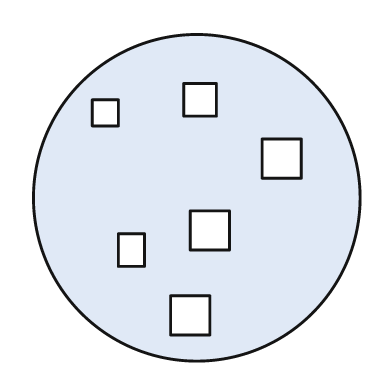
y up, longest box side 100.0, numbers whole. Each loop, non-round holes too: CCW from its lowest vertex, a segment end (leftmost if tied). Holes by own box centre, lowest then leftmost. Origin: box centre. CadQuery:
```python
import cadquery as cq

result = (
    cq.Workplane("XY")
    .moveTo(0.0, 0.0)
    .circle(50.0)
    .moveTo(-8.0, -42.0)
    .lineTo(4.0, -42.0)
    .lineTo(4.0, -30.0)
    .lineTo(-8.0, -30.0)
    .close()
    .moveTo(-24.0, -21.0)
    .lineTo(-16.0, -21.0)
    .lineTo(-16.0, -11.0)
    .lineTo(-24.0, -11.0)
    .close()
    .moveTo(-2.0, -16.0)
    .lineTo(10.0, -16.0)
    .lineTo(10.0, -4.0)
    .lineTo(-2.0, -4.0)
    .close()
    .moveTo(20.0, 6.0)
    .lineTo(32.0, 6.0)
    .lineTo(32.0, 18.0)
    .lineTo(20.0, 18.0)
    .close()
    .moveTo(-32.0, 22.0)
    .lineTo(-24.0, 22.0)
    .lineTo(-24.0, 30.0)
    .lineTo(-32.0, 30.0)
    .close()
    .moveTo(-4.0, 25.0)
    .lineTo(6.0, 25.0)
    .lineTo(6.0, 35.0)
    .lineTo(-4.0, 35.0)
    .close()
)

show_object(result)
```